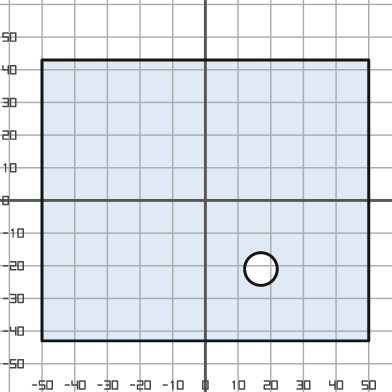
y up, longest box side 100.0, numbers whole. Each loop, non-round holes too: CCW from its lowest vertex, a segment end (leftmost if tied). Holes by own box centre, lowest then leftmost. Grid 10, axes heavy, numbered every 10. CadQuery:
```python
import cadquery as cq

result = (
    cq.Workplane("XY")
    .moveTo(-50.0, -43.0)
    .lineTo(50.0, -43.0)
    .lineTo(50.0, 43.0)
    .lineTo(-50.0, 43.0)
    .close()
    .moveTo(17.0, -21.0)
    .circle(5.0)
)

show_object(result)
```